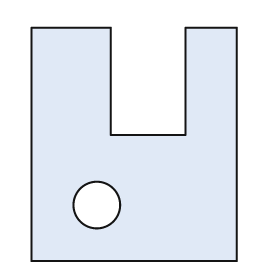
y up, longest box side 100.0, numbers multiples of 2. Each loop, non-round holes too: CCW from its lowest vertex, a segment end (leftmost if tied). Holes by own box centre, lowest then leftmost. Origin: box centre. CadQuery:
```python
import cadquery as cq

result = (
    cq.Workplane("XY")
    .moveTo(-44.0, -50.0)
    .lineTo(44.0, -50.0)
    .lineTo(44.0, 50.0)
    .lineTo(22.0, 50.0)
    .lineTo(22.0, 4.0)
    .lineTo(-10.0, 4.0)
    .lineTo(-10.0, 50.0)
    .lineTo(-44.0, 50.0)
    .close()
    .moveTo(-16.0, -26.0)
    .circle(10.0)
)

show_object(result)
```